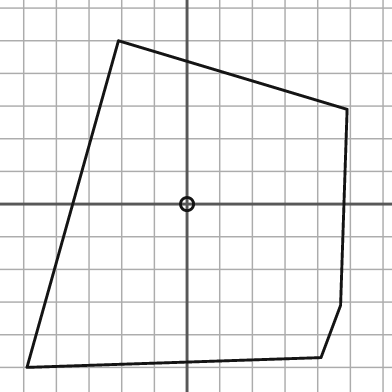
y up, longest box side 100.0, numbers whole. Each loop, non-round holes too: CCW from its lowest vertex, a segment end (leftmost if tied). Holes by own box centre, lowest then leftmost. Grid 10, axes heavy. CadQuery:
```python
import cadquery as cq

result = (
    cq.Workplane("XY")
    .moveTo(-49.0, -50.0)
    .lineTo(41.0, -47.0)
    .lineTo(47.0, -31.0)
    .lineTo(49.0, 29.0)
    .lineTo(-21.0, 50.0)
    .close()
    .moveTo(0.0, 0.0)
    .circle(2.0)
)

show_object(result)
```